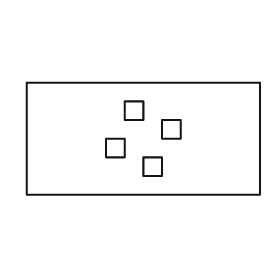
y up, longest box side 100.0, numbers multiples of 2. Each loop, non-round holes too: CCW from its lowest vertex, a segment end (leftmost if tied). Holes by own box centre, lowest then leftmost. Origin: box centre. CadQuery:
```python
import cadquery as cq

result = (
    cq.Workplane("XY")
    .moveTo(-50.0, -24.0)
    .lineTo(50.0, -24.0)
    .lineTo(50.0, 24.0)
    .lineTo(-50.0, 24.0)
    .close()
    .moveTo(0.0, -16.0)
    .lineTo(8.0, -16.0)
    .lineTo(8.0, -8.0)
    .lineTo(0.0, -8.0)
    .close()
    .moveTo(-16.0, -8.0)
    .lineTo(-8.0, -8.0)
    .lineTo(-8.0, 0.0)
    .lineTo(-16.0, 0.0)
    .close()
    .moveTo(8.0, 0.0)
    .lineTo(16.0, 0.0)
    .lineTo(16.0, 8.0)
    .lineTo(8.0, 8.0)
    .close()
    .moveTo(-8.0, 8.0)
    .lineTo(0.0, 8.0)
    .lineTo(0.0, 16.0)
    .lineTo(-8.0, 16.0)
    .close()
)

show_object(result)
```